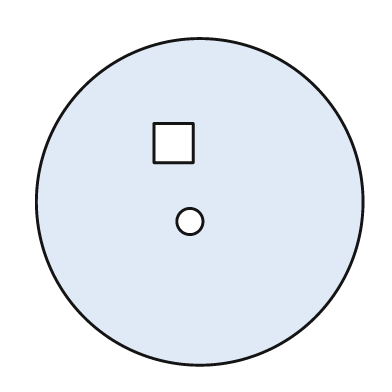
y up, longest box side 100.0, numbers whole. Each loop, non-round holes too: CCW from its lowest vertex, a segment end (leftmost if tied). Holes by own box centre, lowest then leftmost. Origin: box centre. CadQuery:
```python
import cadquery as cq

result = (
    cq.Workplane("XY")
    .moveTo(0.0, 0.0)
    .circle(50.0)
    .moveTo(-3.0, -6.0)
    .circle(4.0)
    .moveTo(-14.0, 12.0)
    .lineTo(-2.0, 12.0)
    .lineTo(-2.0, 24.0)
    .lineTo(-14.0, 24.0)
    .close()
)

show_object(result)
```